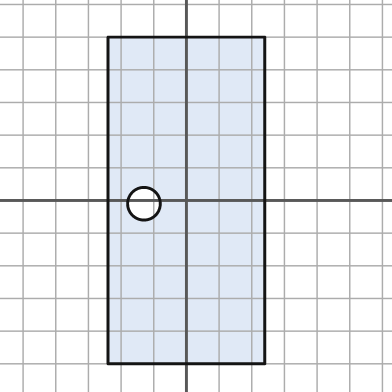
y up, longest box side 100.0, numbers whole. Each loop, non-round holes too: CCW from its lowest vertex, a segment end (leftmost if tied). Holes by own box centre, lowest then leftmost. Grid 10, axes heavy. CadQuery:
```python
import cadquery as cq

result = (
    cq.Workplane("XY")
    .moveTo(-24.0, -50.0)
    .lineTo(24.0, -50.0)
    .lineTo(24.0, 50.0)
    .lineTo(-24.0, 50.0)
    .close()
    .moveTo(-13.0, -1.0)
    .circle(5.0)
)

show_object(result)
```